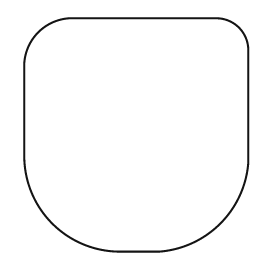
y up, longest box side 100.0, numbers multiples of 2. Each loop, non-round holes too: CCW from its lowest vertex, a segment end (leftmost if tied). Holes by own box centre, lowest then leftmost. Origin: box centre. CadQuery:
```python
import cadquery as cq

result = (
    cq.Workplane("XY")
    .moveTo(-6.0, -50.0)
    .lineTo(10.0, -50.0)
    .threePointArc((36.0, -38.0), (48.0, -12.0))
    .lineTo(48.0, 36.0)
    .threePointArc((44.0, 46.0), (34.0, 50.0))
    .lineTo(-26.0, 50.0)
    .threePointArc((-42.0, 44.0), (-48.0, 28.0))
    .lineTo(-48.0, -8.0)
    .threePointArc((-36.0, -38.0), (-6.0, -50.0))
    .close()
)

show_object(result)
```